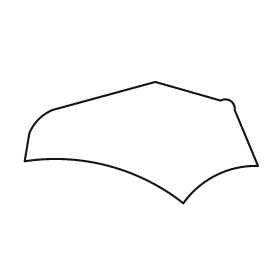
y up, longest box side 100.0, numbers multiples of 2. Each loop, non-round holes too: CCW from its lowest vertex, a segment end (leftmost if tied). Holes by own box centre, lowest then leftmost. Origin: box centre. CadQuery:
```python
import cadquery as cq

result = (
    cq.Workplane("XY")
    .moveTo(18.0, -26.0)
    .threePointArc((32.0, -14.0), (50.0, -10.0))
    .lineTo(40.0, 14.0)
    .threePointArc((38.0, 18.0), (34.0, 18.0))
    .lineTo(6.0, 26.0)
    .lineTo(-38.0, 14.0)
    .threePointArc((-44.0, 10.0), (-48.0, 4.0))
    .lineTo(-50.0, -8.0)
    .threePointArc((-14.0, -10.0), (18.0, -26.0))
    .close()
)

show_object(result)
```